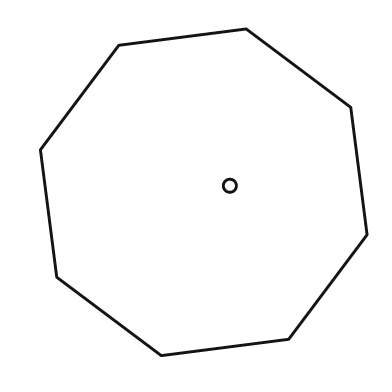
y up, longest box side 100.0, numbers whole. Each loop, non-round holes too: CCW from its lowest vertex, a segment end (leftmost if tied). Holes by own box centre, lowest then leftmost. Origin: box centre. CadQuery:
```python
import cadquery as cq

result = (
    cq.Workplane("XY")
    .moveTo(-13.0, -50.0)
    .lineTo(26.0, -45.0)
    .lineTo(50.0, -13.0)
    .lineTo(45.0, 26.0)
    .lineTo(13.0, 50.0)
    .lineTo(-26.0, 45.0)
    .lineTo(-50.0, 13.0)
    .lineTo(-45.0, -26.0)
    .close()
    .moveTo(8.0, 2.0)
    .circle(2.0)
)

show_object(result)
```